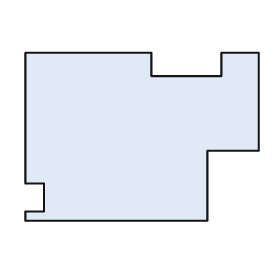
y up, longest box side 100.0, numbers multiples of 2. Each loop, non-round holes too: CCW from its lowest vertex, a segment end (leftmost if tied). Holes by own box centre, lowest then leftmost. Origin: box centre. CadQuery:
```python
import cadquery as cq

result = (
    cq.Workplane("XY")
    .moveTo(-50.0, -36.0)
    .lineTo(28.0, -36.0)
    .lineTo(28.0, -6.0)
    .lineTo(50.0, -6.0)
    .lineTo(50.0, 36.0)
    .lineTo(34.0, 36.0)
    .lineTo(34.0, 26.0)
    .lineTo(4.0, 26.0)
    .lineTo(4.0, 36.0)
    .lineTo(-50.0, 36.0)
    .lineTo(-50.0, -20.0)
    .lineTo(-42.0, -20.0)
    .lineTo(-42.0, -32.0)
    .lineTo(-50.0, -32.0)
    .close()
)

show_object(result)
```